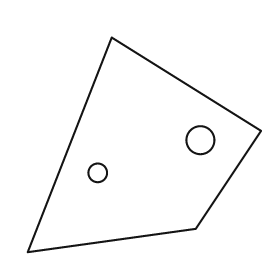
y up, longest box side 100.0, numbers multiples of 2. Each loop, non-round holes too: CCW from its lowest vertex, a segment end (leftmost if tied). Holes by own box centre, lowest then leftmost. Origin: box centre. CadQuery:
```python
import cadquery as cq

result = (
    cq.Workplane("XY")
    .moveTo(-50.0, -46.0)
    .lineTo(22.0, -36.0)
    .lineTo(50.0, 6.0)
    .lineTo(-14.0, 46.0)
    .close()
    .moveTo(-20.0, -12.0)
    .circle(4.0)
    .moveTo(24.0, 2.0)
    .circle(6.0)
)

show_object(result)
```